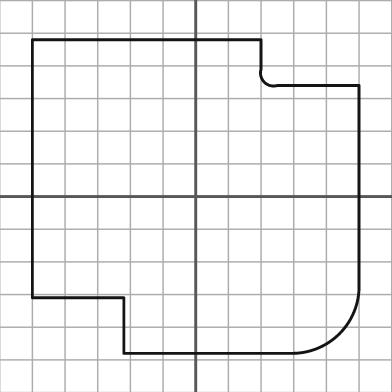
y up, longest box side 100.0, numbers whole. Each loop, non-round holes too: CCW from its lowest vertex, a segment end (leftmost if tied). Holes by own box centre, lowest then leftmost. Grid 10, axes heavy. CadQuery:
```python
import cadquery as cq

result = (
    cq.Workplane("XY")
    .moveTo(-22.0, -48.0)
    .lineTo(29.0, -48.0)
    .threePointArc((44.0, -42.0), (50.0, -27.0))
    .lineTo(50.0, 34.0)
    .lineTo(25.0, 34.0)
    .threePointArc((21.0, 35.0), (20.0, 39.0))
    .lineTo(20.0, 48.0)
    .lineTo(-50.0, 48.0)
    .lineTo(-50.0, -31.0)
    .lineTo(-22.0, -31.0)
    .close()
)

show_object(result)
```